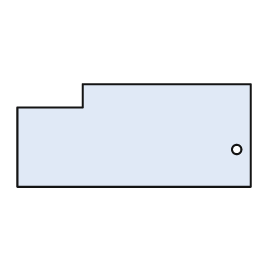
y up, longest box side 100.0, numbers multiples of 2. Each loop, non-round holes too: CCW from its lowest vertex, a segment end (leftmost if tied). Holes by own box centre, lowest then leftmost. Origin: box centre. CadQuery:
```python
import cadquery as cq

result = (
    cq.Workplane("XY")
    .moveTo(-50.0, -22.0)
    .lineTo(50.0, -22.0)
    .lineTo(50.0, 22.0)
    .lineTo(-22.0, 22.0)
    .lineTo(-22.0, 12.0)
    .lineTo(-50.0, 12.0)
    .close()
    .moveTo(44.0, -6.0)
    .circle(2.0)
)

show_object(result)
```